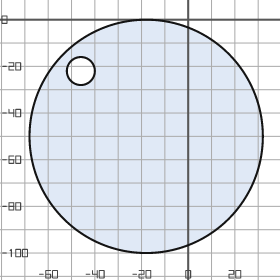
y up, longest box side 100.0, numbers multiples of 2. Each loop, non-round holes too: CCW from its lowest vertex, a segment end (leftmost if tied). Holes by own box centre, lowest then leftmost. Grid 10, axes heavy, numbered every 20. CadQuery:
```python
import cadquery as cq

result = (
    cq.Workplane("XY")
    .moveTo(-18.0, -50.0)
    .circle(50.0)
    .moveTo(-46.0, -22.0)
    .circle(6.0)
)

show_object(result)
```